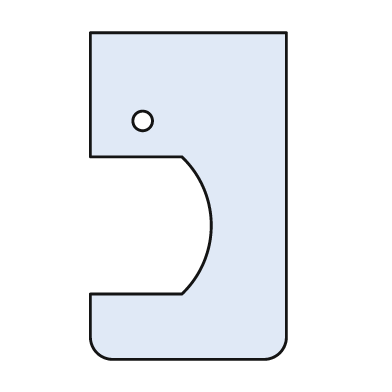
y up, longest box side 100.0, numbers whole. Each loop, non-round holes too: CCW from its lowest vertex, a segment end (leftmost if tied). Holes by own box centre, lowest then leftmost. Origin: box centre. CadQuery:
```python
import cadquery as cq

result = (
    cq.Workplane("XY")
    .moveTo(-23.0, -50.0)
    .lineTo(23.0, -50.0)
    .threePointArc((28.0, -48.0), (30.0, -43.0))
    .lineTo(30.0, 50.0)
    .lineTo(-30.0, 50.0)
    .lineTo(-30.0, 12.0)
    .lineTo(-2.0, 12.0)
    .threePointArc((7.0, -9.0), (-2.0, -30.0))
    .lineTo(-30.0, -30.0)
    .lineTo(-30.0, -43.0)
    .threePointArc((-28.0, -48.0), (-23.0, -50.0))
    .close()
    .moveTo(-14.0, 23.0)
    .circle(3.0)
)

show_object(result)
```